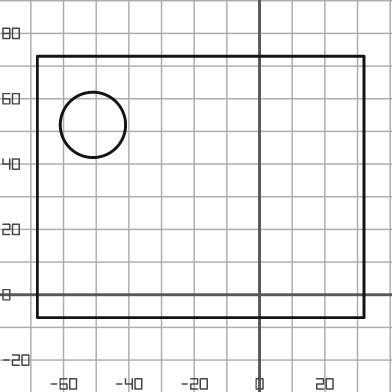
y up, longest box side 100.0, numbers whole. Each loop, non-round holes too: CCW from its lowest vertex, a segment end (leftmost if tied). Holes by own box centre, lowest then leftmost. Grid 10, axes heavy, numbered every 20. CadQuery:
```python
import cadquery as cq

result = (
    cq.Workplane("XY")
    .moveTo(-68.0, -7.0)
    .lineTo(32.0, -7.0)
    .lineTo(32.0, 73.0)
    .lineTo(-68.0, 73.0)
    .close()
    .moveTo(-51.0, 52.0)
    .circle(10.0)
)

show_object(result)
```